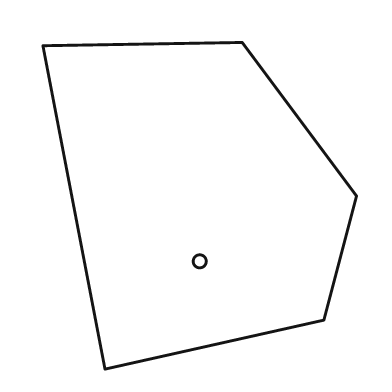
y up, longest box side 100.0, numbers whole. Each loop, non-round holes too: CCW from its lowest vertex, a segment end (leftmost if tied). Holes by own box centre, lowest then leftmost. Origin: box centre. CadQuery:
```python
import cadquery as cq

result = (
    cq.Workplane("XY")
    .moveTo(-29.0, -50.0)
    .lineTo(38.0, -35.0)
    .lineTo(48.0, 3.0)
    .lineTo(13.0, 50.0)
    .lineTo(-48.0, 49.0)
    .close()
    .moveTo(0.0, -17.0)
    .circle(2.0)
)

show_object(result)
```